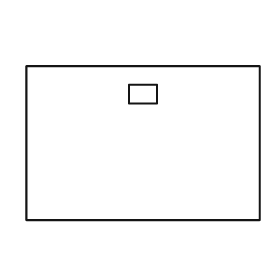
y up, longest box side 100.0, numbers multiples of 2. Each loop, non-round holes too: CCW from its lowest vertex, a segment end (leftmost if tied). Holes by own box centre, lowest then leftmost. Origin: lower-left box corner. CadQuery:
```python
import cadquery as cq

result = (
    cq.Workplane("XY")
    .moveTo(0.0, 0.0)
    .lineTo(100.0, 0.0)
    .lineTo(100.0, 66.0)
    .lineTo(0.0, 66.0)
    .close()
    .moveTo(44.0, 50.0)
    .lineTo(56.0, 50.0)
    .lineTo(56.0, 58.0)
    .lineTo(44.0, 58.0)
    .close()
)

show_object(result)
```